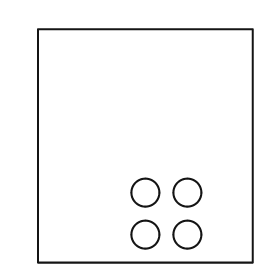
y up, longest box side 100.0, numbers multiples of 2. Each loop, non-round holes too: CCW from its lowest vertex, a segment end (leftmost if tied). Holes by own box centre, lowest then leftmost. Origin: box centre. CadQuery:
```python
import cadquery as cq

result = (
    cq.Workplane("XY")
    .moveTo(-46.0, -50.0)
    .lineTo(46.0, -50.0)
    .lineTo(46.0, 50.0)
    .lineTo(-46.0, 50.0)
    .close()
    .moveTo(0.0, -38.0)
    .circle(6.0)
    .moveTo(18.0, -38.0)
    .circle(6.0)
    .moveTo(0.0, -20.0)
    .circle(6.0)
    .moveTo(18.0, -20.0)
    .circle(6.0)
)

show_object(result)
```